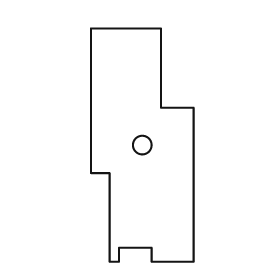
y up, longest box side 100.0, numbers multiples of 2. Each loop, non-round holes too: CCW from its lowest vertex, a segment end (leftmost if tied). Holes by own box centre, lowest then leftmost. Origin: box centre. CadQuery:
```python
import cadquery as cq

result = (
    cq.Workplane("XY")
    .moveTo(-14.0, -50.0)
    .lineTo(-10.0, -50.0)
    .lineTo(-10.0, -44.0)
    .lineTo(4.0, -44.0)
    .lineTo(4.0, -50.0)
    .lineTo(22.0, -50.0)
    .lineTo(22.0, 16.0)
    .lineTo(8.0, 16.0)
    .lineTo(8.0, 50.0)
    .lineTo(-22.0, 50.0)
    .lineTo(-22.0, -12.0)
    .lineTo(-14.0, -12.0)
    .close()
    .moveTo(0.0, 0.0)
    .circle(4.0)
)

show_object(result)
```